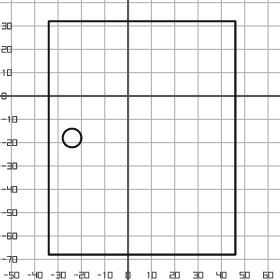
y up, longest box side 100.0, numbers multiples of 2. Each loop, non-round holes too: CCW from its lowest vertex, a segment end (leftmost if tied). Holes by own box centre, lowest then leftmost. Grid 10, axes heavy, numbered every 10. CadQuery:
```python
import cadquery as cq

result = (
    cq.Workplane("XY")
    .moveTo(-34.0, -68.0)
    .lineTo(46.0, -68.0)
    .lineTo(46.0, 32.0)
    .lineTo(-34.0, 32.0)
    .close()
    .moveTo(-24.0, -18.0)
    .circle(4.0)
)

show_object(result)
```